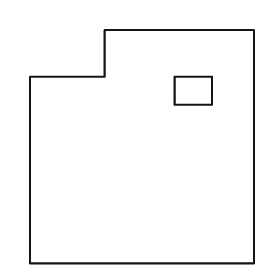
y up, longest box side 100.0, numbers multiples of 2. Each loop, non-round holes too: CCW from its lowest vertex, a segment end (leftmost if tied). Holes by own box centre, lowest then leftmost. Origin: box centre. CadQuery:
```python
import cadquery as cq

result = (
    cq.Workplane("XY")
    .moveTo(-48.0, -50.0)
    .lineTo(48.0, -50.0)
    .lineTo(48.0, 50.0)
    .lineTo(-16.0, 50.0)
    .lineTo(-16.0, 30.0)
    .lineTo(-48.0, 30.0)
    .close()
    .moveTo(14.0, 18.0)
    .lineTo(30.0, 18.0)
    .lineTo(30.0, 30.0)
    .lineTo(14.0, 30.0)
    .close()
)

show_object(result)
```